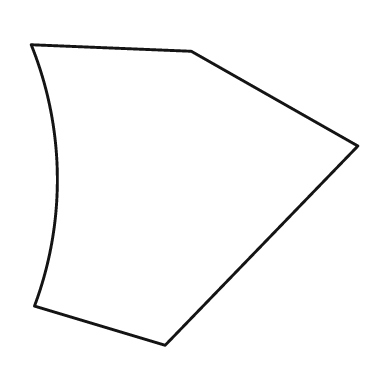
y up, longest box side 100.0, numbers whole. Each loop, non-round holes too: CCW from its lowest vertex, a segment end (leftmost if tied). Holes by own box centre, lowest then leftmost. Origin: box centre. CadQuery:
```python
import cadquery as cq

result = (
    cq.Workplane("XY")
    .moveTo(-9.0, -46.0)
    .lineTo(50.0, 15.0)
    .lineTo(-1.0, 44.0)
    .lineTo(-50.0, 46.0)
    .threePointArc((-42.0, 6.0), (-49.0, -34.0))
    .close()
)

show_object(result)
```